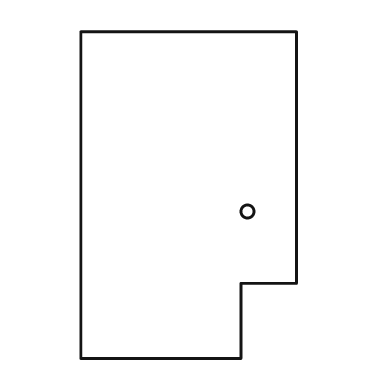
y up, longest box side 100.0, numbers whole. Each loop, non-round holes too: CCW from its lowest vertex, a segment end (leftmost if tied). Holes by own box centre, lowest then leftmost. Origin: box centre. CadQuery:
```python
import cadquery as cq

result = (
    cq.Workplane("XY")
    .moveTo(-33.0, -50.0)
    .lineTo(16.0, -50.0)
    .lineTo(16.0, -27.0)
    .lineTo(33.0, -27.0)
    .lineTo(33.0, 50.0)
    .lineTo(-33.0, 50.0)
    .close()
    .moveTo(18.0, -5.0)
    .circle(2.0)
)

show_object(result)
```